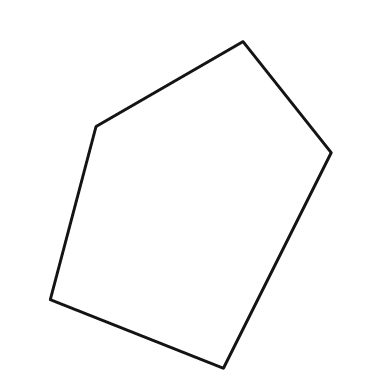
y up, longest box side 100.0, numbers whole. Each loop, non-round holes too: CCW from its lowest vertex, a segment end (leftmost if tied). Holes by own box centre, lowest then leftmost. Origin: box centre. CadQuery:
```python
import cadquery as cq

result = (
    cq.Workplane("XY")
    .moveTo(10.0, -50.0)
    .lineTo(43.0, 16.0)
    .lineTo(16.0, 50.0)
    .lineTo(-29.0, 24.0)
    .lineTo(-43.0, -29.0)
    .close()
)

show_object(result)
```